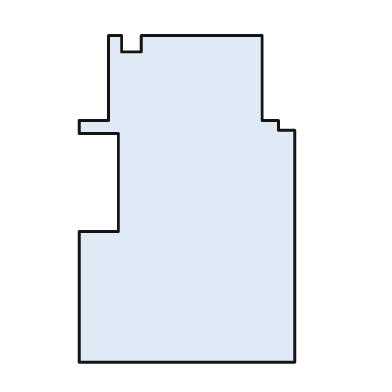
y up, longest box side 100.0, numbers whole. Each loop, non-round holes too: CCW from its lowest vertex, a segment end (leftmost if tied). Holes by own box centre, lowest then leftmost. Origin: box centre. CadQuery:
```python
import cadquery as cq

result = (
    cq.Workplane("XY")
    .moveTo(-33.0, -50.0)
    .lineTo(33.0, -50.0)
    .lineTo(33.0, 21.0)
    .lineTo(28.0, 21.0)
    .lineTo(28.0, 24.0)
    .lineTo(23.0, 24.0)
    .lineTo(23.0, 50.0)
    .lineTo(-14.0, 50.0)
    .lineTo(-14.0, 45.0)
    .lineTo(-20.0, 45.0)
    .lineTo(-20.0, 50.0)
    .lineTo(-24.0, 50.0)
    .lineTo(-24.0, 24.0)
    .lineTo(-33.0, 24.0)
    .lineTo(-33.0, 20.0)
    .lineTo(-21.0, 20.0)
    .lineTo(-21.0, -10.0)
    .lineTo(-33.0, -10.0)
    .close()
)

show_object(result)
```